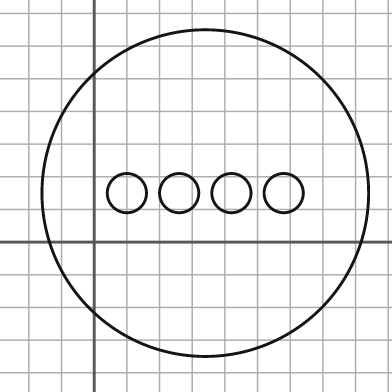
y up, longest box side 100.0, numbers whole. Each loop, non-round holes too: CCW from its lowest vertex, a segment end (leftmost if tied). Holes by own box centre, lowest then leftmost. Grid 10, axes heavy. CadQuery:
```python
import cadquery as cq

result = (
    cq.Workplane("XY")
    .moveTo(34.0, 15.0)
    .circle(50.0)
    .moveTo(10.0, 15.0)
    .circle(6.0)
    .moveTo(26.0, 15.0)
    .circle(6.0)
    .moveTo(42.0, 15.0)
    .circle(6.0)
    .moveTo(58.0, 15.0)
    .circle(6.0)
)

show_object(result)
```